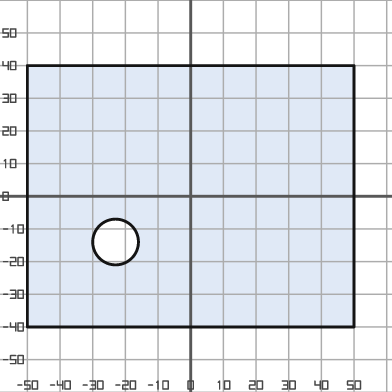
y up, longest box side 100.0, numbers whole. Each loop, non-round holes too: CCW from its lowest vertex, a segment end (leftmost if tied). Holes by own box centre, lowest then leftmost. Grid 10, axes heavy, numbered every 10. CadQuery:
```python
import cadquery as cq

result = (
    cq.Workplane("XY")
    .moveTo(-50.0, -40.0)
    .lineTo(50.0, -40.0)
    .lineTo(50.0, 40.0)
    .lineTo(-50.0, 40.0)
    .close()
    .moveTo(-23.0, -14.0)
    .circle(7.0)
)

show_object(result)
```